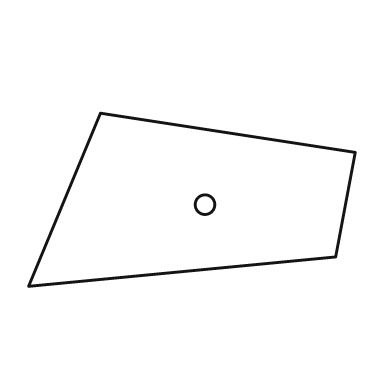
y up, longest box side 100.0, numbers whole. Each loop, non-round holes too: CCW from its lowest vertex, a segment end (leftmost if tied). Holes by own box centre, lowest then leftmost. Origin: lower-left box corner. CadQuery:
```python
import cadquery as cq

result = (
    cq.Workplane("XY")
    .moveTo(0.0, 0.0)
    .lineTo(94.0, 9.0)
    .lineTo(100.0, 41.0)
    .lineTo(22.0, 53.0)
    .close()
    .moveTo(54.0, 25.0)
    .circle(3.0)
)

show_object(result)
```